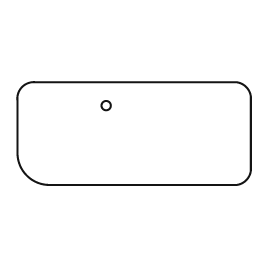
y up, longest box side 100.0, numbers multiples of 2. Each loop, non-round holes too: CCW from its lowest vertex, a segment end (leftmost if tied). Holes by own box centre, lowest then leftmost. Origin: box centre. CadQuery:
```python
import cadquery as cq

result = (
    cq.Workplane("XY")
    .moveTo(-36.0, -22.0)
    .lineTo(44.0, -22.0)
    .threePointArc((48.0, -20.0), (50.0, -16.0))
    .lineTo(50.0, 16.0)
    .threePointArc((48.0, 20.0), (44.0, 22.0))
    .lineTo(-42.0, 22.0)
    .threePointArc((-48.0, 20.0), (-50.0, 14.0))
    .lineTo(-50.0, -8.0)
    .threePointArc((-46.0, -18.0), (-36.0, -22.0))
    .close()
    .moveTo(-12.0, 12.0)
    .circle(2.0)
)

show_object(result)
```